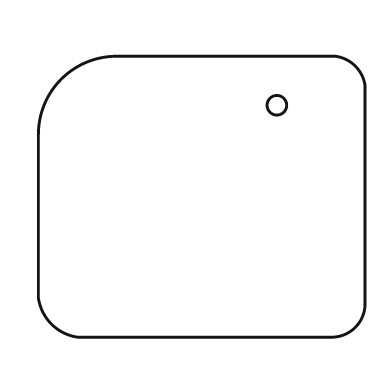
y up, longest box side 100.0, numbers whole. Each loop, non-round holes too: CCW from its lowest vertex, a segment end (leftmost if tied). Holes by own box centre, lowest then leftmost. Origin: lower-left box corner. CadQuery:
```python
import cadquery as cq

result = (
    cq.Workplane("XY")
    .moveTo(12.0, 0.0)
    .lineTo(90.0, 0.0)
    .threePointArc((97.0, 3.0), (100.0, 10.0))
    .lineTo(100.0, 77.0)
    .threePointArc((97.0, 83.0), (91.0, 86.0))
    .lineTo(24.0, 86.0)
    .threePointArc((7.0, 79.0), (0.0, 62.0))
    .lineTo(0.0, 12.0)
    .threePointArc((4.0, 4.0), (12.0, 0.0))
    .close()
    .moveTo(73.0, 71.0)
    .circle(3.0)
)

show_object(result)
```